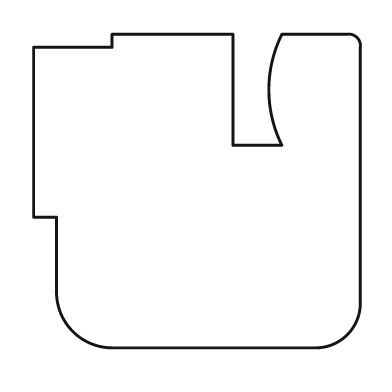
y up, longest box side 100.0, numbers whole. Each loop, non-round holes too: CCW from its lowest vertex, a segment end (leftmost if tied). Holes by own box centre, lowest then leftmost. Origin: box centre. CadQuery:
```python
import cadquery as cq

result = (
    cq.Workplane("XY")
    .moveTo(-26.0, -48.0)
    .lineTo(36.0, -48.0)
    .threePointArc((46.0, -44.0), (50.0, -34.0))
    .lineTo(50.0, 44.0)
    .threePointArc((49.0, 47.0), (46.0, 48.0))
    .lineTo(26.0, 48.0)
    .threePointArc((22.0, 31.0), (26.0, 14.0))
    .lineTo(11.0, 14.0)
    .lineTo(11.0, 48.0)
    .lineTo(-26.0, 48.0)
    .lineTo(-26.0, 44.0)
    .lineTo(-50.0, 44.0)
    .lineTo(-50.0, -8.0)
    .lineTo(-43.0, -8.0)
    .lineTo(-43.0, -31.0)
    .threePointArc((-38.0, -43.0), (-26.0, -48.0))
    .close()
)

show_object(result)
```